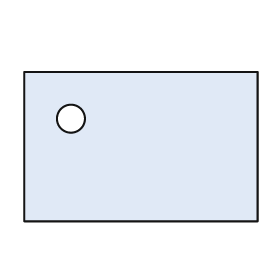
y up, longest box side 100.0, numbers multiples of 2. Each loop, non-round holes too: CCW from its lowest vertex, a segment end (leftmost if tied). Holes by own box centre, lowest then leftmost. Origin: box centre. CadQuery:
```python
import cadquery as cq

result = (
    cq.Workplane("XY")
    .moveTo(-50.0, -32.0)
    .lineTo(50.0, -32.0)
    .lineTo(50.0, 32.0)
    .lineTo(-50.0, 32.0)
    .close()
    .moveTo(-30.0, 12.0)
    .circle(6.0)
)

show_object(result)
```